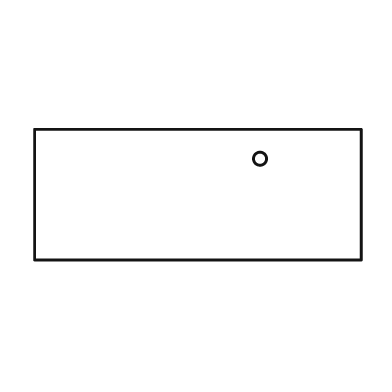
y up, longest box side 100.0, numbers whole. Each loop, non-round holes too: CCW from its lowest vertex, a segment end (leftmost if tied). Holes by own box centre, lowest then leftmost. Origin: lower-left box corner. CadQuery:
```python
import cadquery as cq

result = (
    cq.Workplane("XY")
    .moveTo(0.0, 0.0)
    .lineTo(100.0, 0.0)
    .lineTo(100.0, 40.0)
    .lineTo(0.0, 40.0)
    .close()
    .moveTo(69.0, 31.0)
    .circle(2.0)
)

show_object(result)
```